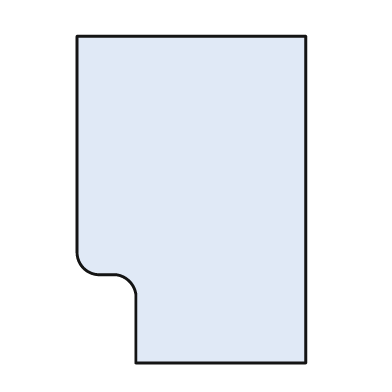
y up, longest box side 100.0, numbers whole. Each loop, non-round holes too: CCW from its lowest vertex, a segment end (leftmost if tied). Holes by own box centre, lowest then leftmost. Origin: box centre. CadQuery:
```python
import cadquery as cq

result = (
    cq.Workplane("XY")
    .moveTo(-17.0, -50.0)
    .lineTo(35.0, -50.0)
    .lineTo(35.0, 50.0)
    .lineTo(-35.0, 50.0)
    .lineTo(-35.0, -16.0)
    .threePointArc((-33.0, -21.0), (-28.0, -23.0))
    .lineTo(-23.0, -23.0)
    .threePointArc((-19.0, -25.0), (-17.0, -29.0))
    .close()
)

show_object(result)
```